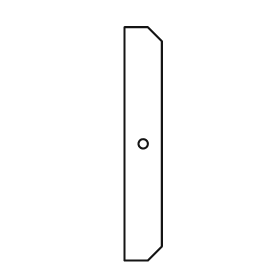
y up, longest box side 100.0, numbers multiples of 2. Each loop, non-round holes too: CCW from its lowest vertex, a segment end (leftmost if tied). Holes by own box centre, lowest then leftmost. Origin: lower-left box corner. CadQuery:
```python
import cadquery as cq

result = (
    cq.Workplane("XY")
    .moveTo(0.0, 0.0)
    .lineTo(10.0, 0.0)
    .lineTo(16.0, 6.0)
    .lineTo(16.0, 94.0)
    .lineTo(10.0, 100.0)
    .lineTo(0.0, 100.0)
    .close()
    .moveTo(8.0, 50.0)
    .circle(2.0)
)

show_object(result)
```